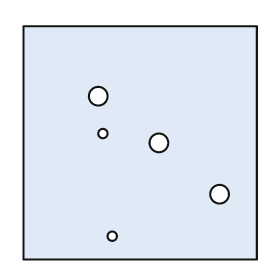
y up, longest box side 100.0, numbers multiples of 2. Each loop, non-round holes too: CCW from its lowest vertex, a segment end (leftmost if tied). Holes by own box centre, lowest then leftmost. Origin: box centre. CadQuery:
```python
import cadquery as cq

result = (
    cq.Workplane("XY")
    .moveTo(-50.0, -50.0)
    .lineTo(50.0, -50.0)
    .lineTo(50.0, 50.0)
    .lineTo(-50.0, 50.0)
    .close()
    .moveTo(-12.0, -40.0)
    .circle(2.0)
    .moveTo(34.0, -22.0)
    .circle(4.0)
    .moveTo(8.0, 0.0)
    .circle(4.0)
    .moveTo(-16.0, 4.0)
    .circle(2.0)
    .moveTo(-18.0, 20.0)
    .circle(4.0)
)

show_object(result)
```